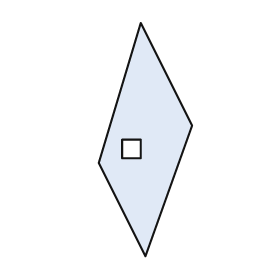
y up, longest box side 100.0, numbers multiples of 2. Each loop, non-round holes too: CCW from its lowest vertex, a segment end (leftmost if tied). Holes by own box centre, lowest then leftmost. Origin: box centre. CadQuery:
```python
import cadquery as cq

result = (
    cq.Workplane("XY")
    .moveTo(0.0, -50.0)
    .lineTo(20.0, 6.0)
    .lineTo(-2.0, 50.0)
    .lineTo(-20.0, -10.0)
    .close()
    .moveTo(-10.0, -8.0)
    .lineTo(-2.0, -8.0)
    .lineTo(-2.0, 0.0)
    .lineTo(-10.0, 0.0)
    .close()
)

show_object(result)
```